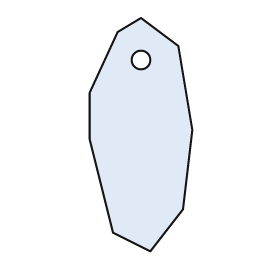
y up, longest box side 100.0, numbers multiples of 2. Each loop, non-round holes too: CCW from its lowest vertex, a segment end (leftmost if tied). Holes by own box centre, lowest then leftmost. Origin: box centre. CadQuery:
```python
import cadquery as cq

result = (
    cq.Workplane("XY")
    .moveTo(4.0, -50.0)
    .lineTo(18.0, -32.0)
    .lineTo(22.0, 2.0)
    .lineTo(16.0, 38.0)
    .lineTo(0.0, 50.0)
    .lineTo(-10.0, 44.0)
    .lineTo(-22.0, 18.0)
    .lineTo(-22.0, -2.0)
    .lineTo(-12.0, -42.0)
    .close()
    .moveTo(0.0, 32.0)
    .circle(4.0)
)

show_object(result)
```